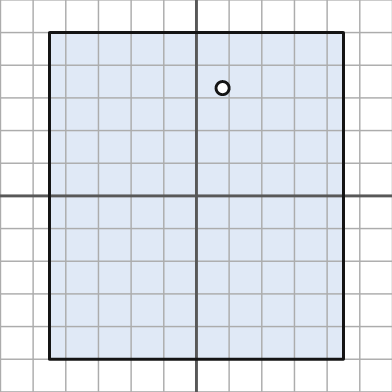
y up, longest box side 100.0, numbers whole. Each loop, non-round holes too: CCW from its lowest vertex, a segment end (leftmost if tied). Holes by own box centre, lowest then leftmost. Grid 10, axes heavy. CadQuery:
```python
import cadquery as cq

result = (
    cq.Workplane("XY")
    .moveTo(-45.0, -50.0)
    .lineTo(45.0, -50.0)
    .lineTo(45.0, 50.0)
    .lineTo(-45.0, 50.0)
    .close()
    .moveTo(8.0, 33.0)
    .circle(2.0)
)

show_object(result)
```